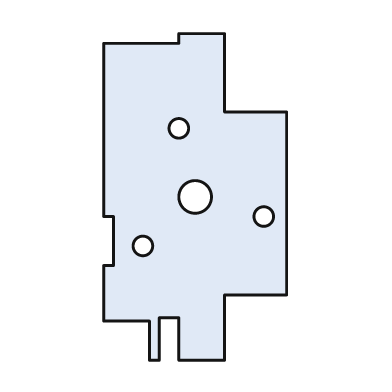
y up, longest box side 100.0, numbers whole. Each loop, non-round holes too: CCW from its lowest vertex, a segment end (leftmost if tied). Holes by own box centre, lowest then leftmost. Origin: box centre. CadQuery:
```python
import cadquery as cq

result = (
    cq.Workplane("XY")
    .moveTo(-14.0, -50.0)
    .lineTo(-11.0, -50.0)
    .lineTo(-11.0, -37.0)
    .lineTo(-5.0, -37.0)
    .lineTo(-5.0, -50.0)
    .lineTo(9.0, -50.0)
    .lineTo(9.0, -30.0)
    .lineTo(28.0, -30.0)
    .lineTo(28.0, 26.0)
    .lineTo(9.0, 26.0)
    .lineTo(9.0, 50.0)
    .lineTo(-5.0, 50.0)
    .lineTo(-5.0, 47.0)
    .lineTo(-28.0, 47.0)
    .lineTo(-28.0, -6.0)
    .lineTo(-25.0, -6.0)
    .lineTo(-25.0, -21.0)
    .lineTo(-28.0, -21.0)
    .lineTo(-28.0, -38.0)
    .lineTo(-14.0, -38.0)
    .close()
    .moveTo(-16.0, -15.0)
    .circle(3.0)
    .moveTo(21.0, -6.0)
    .circle(3.0)
    .moveTo(0.0, 0.0)
    .circle(5.0)
    .moveTo(-5.0, 21.0)
    .circle(3.0)
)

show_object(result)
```